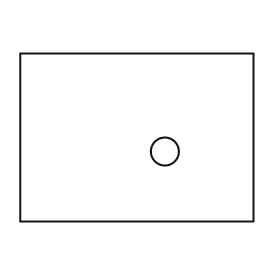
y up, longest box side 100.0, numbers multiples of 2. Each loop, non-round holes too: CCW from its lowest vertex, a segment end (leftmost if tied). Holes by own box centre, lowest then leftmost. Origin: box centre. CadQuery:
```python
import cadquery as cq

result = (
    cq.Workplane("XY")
    .moveTo(-50.0, -36.0)
    .lineTo(50.0, -36.0)
    .lineTo(50.0, 36.0)
    .lineTo(-50.0, 36.0)
    .close()
    .moveTo(12.0, -6.0)
    .circle(6.0)
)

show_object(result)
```